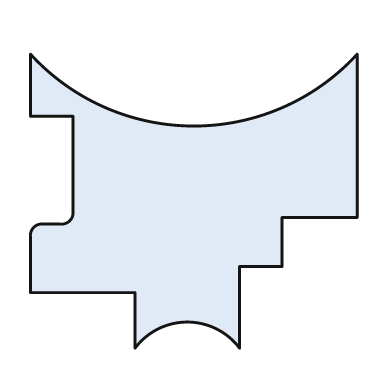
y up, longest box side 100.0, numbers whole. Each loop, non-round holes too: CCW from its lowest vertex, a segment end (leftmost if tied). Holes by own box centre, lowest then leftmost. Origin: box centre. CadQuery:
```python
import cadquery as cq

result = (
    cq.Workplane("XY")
    .moveTo(-18.0, -45.0)
    .threePointArc((-2.0, -37.0), (14.0, -45.0))
    .lineTo(14.0, -20.0)
    .lineTo(27.0, -20.0)
    .lineTo(27.0, -5.0)
    .lineTo(50.0, -5.0)
    .lineTo(50.0, 45.0)
    .threePointArc((0.0, 23.0), (-50.0, 45.0))
    .lineTo(-50.0, 26.0)
    .lineTo(-37.0, 26.0)
    .lineTo(-37.0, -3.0)
    .threePointArc((-38.0, -6.0), (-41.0, -7.0))
    .lineTo(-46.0, -7.0)
    .threePointArc((-49.0, -8.0), (-50.0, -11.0))
    .lineTo(-50.0, -28.0)
    .lineTo(-18.0, -28.0)
    .close()
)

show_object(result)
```